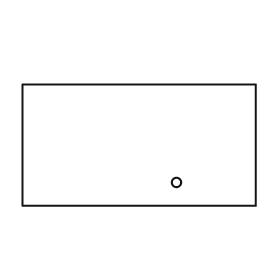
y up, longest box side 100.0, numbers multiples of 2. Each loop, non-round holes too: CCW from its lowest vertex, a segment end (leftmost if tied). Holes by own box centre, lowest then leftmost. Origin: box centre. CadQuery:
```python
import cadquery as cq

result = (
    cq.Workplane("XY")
    .moveTo(-50.0, -26.0)
    .lineTo(50.0, -26.0)
    .lineTo(50.0, 26.0)
    .lineTo(-50.0, 26.0)
    .close()
    .moveTo(16.0, -16.0)
    .circle(2.0)
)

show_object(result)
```